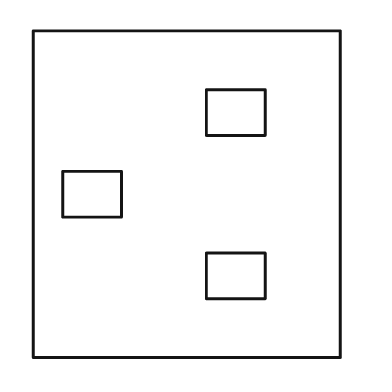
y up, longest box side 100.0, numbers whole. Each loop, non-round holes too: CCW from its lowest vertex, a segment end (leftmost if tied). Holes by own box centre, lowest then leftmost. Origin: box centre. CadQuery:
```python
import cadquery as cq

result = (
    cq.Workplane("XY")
    .moveTo(-47.0, -50.0)
    .lineTo(47.0, -50.0)
    .lineTo(47.0, 50.0)
    .lineTo(-47.0, 50.0)
    .close()
    .moveTo(6.0, -32.0)
    .lineTo(24.0, -32.0)
    .lineTo(24.0, -18.0)
    .lineTo(6.0, -18.0)
    .close()
    .moveTo(-38.0, -7.0)
    .lineTo(-20.0, -7.0)
    .lineTo(-20.0, 7.0)
    .lineTo(-38.0, 7.0)
    .close()
    .moveTo(6.0, 18.0)
    .lineTo(24.0, 18.0)
    .lineTo(24.0, 32.0)
    .lineTo(6.0, 32.0)
    .close()
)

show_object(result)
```